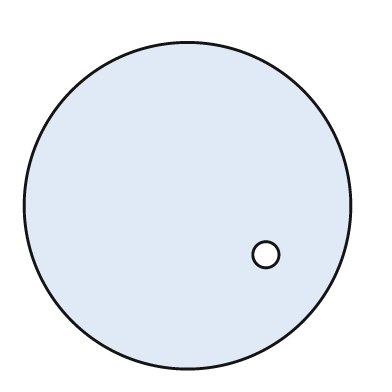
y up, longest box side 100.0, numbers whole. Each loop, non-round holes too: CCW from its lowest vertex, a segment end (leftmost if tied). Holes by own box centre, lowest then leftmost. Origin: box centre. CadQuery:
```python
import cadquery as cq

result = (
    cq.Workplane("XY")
    .moveTo(0.0, 0.0)
    .circle(50.0)
    .moveTo(24.0, -15.0)
    .circle(4.0)
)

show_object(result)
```